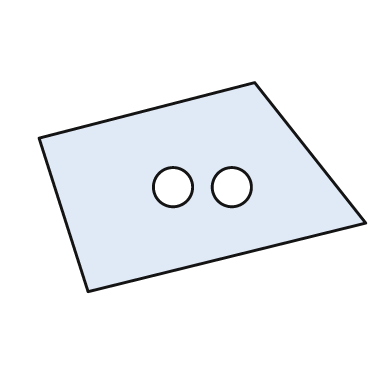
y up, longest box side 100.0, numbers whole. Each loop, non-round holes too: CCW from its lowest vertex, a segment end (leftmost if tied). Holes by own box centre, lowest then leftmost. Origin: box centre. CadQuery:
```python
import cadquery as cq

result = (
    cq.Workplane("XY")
    .moveTo(-35.0, -32.0)
    .lineTo(50.0, -11.0)
    .lineTo(16.0, 32.0)
    .lineTo(-50.0, 15.0)
    .close()
    .moveTo(-9.0, 0.0)
    .circle(6.0)
    .moveTo(9.0, 0.0)
    .circle(6.0)
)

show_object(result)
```